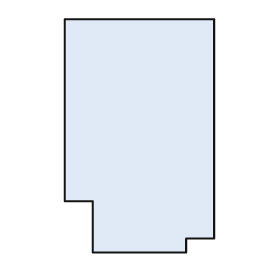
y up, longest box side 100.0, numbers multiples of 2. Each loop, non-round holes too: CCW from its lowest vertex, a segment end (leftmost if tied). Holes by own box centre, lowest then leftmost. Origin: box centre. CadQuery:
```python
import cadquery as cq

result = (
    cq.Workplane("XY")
    .moveTo(-20.0, -50.0)
    .lineTo(20.0, -50.0)
    .lineTo(20.0, -44.0)
    .lineTo(32.0, -44.0)
    .lineTo(32.0, 50.0)
    .lineTo(-32.0, 50.0)
    .lineTo(-32.0, -28.0)
    .lineTo(-20.0, -28.0)
    .close()
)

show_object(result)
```